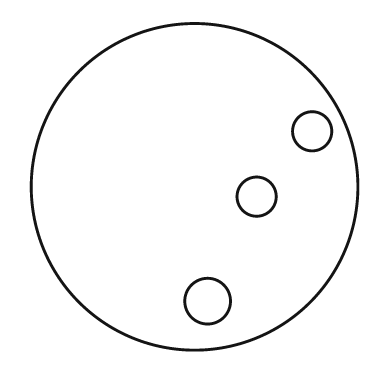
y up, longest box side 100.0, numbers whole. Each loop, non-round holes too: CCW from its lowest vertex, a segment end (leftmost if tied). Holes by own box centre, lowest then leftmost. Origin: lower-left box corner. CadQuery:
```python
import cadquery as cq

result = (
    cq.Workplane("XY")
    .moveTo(50.0, 50.0)
    .circle(50.0)
    .moveTo(54.0, 15.0)
    .circle(7.0)
    .moveTo(69.0, 47.0)
    .circle(6.0)
    .moveTo(86.0, 67.0)
    .circle(6.0)
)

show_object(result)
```